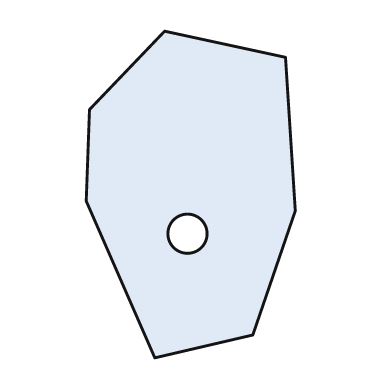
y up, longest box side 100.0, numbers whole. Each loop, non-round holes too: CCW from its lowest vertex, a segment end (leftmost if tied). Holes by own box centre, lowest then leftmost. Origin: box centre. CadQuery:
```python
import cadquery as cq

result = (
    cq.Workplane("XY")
    .moveTo(-11.0, -50.0)
    .lineTo(19.0, -43.0)
    .lineTo(32.0, -5.0)
    .lineTo(29.0, 42.0)
    .lineTo(-8.0, 50.0)
    .lineTo(-31.0, 26.0)
    .lineTo(-32.0, -2.0)
    .close()
    .moveTo(-1.0, -12.0)
    .circle(6.0)
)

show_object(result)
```